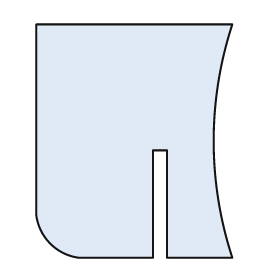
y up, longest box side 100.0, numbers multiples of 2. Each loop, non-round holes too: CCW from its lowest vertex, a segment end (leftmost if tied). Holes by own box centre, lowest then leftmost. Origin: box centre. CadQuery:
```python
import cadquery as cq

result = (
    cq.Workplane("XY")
    .moveTo(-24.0, -50.0)
    .lineTo(8.0, -50.0)
    .lineTo(8.0, -4.0)
    .lineTo(14.0, -4.0)
    .lineTo(14.0, -50.0)
    .lineTo(42.0, -50.0)
    .threePointArc((34.0, 0.0), (42.0, 50.0))
    .lineTo(-42.0, 50.0)
    .lineTo(-42.0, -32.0)
    .threePointArc((-36.0, -44.0), (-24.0, -50.0))
    .close()
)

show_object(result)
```